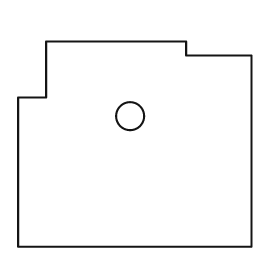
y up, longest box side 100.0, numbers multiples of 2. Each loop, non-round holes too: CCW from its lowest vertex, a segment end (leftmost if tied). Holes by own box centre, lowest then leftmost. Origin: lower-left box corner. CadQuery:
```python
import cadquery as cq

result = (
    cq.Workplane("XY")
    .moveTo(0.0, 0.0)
    .lineTo(100.0, 0.0)
    .lineTo(100.0, 82.0)
    .lineTo(72.0, 82.0)
    .lineTo(72.0, 88.0)
    .lineTo(12.0, 88.0)
    .lineTo(12.0, 64.0)
    .lineTo(0.0, 64.0)
    .close()
    .moveTo(48.0, 56.0)
    .circle(6.0)
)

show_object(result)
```